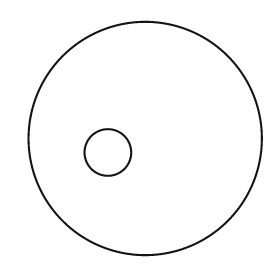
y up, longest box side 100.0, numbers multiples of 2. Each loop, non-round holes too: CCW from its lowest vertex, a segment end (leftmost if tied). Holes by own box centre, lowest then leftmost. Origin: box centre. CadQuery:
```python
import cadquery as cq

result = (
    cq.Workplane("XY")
    .moveTo(0.0, 0.0)
    .circle(50.0)
    .moveTo(-16.0, -6.0)
    .circle(10.0)
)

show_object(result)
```